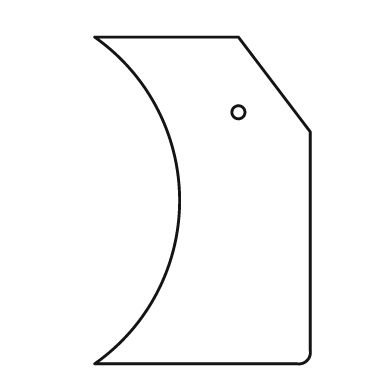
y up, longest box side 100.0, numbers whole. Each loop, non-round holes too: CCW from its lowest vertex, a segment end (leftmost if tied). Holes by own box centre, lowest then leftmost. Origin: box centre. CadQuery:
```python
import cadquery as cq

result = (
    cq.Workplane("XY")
    .moveTo(-33.0, -50.0)
    .lineTo(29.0, -50.0)
    .threePointArc((32.0, -49.0), (33.0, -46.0))
    .lineTo(33.0, 21.0)
    .lineTo(11.0, 50.0)
    .lineTo(-33.0, 50.0)
    .threePointArc((-7.0, 0.0), (-33.0, -50.0))
    .close()
    .moveTo(11.0, 27.0)
    .circle(2.0)
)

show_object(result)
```